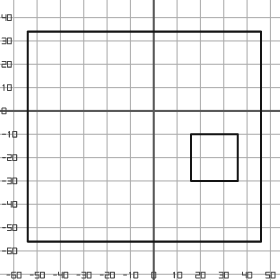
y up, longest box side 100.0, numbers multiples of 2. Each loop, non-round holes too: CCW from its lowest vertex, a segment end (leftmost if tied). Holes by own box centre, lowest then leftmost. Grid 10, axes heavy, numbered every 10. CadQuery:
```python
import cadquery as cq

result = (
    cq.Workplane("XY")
    .moveTo(-54.0, -56.0)
    .lineTo(46.0, -56.0)
    .lineTo(46.0, 34.0)
    .lineTo(-54.0, 34.0)
    .close()
    .moveTo(16.0, -30.0)
    .lineTo(36.0, -30.0)
    .lineTo(36.0, -10.0)
    .lineTo(16.0, -10.0)
    .close()
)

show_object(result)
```